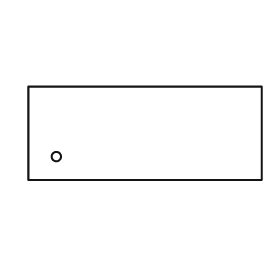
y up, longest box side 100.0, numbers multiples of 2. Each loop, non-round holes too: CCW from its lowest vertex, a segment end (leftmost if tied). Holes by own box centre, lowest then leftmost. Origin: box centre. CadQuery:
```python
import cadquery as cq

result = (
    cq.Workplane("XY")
    .moveTo(-50.0, -20.0)
    .lineTo(50.0, -20.0)
    .lineTo(50.0, 20.0)
    .lineTo(-50.0, 20.0)
    .close()
    .moveTo(-38.0, -10.0)
    .circle(2.0)
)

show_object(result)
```